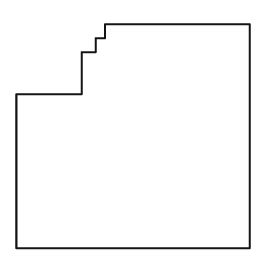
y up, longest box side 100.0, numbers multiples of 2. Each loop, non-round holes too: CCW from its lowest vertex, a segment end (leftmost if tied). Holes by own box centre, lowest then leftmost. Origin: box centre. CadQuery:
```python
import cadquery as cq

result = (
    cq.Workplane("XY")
    .moveTo(-50.0, -48.0)
    .lineTo(50.0, -48.0)
    .lineTo(50.0, 48.0)
    .lineTo(-12.0, 48.0)
    .lineTo(-12.0, 42.0)
    .lineTo(-16.0, 42.0)
    .lineTo(-16.0, 36.0)
    .lineTo(-22.0, 36.0)
    .lineTo(-22.0, 18.0)
    .lineTo(-50.0, 18.0)
    .close()
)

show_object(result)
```